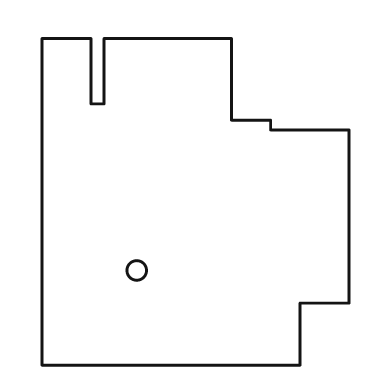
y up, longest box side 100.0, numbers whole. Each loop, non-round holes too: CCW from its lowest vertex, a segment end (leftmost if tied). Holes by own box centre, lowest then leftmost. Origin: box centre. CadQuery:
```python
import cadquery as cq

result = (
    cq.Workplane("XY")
    .moveTo(-47.0, -50.0)
    .lineTo(32.0, -50.0)
    .lineTo(32.0, -31.0)
    .lineTo(47.0, -31.0)
    .lineTo(47.0, 22.0)
    .lineTo(23.0, 22.0)
    .lineTo(23.0, 25.0)
    .lineTo(11.0, 25.0)
    .lineTo(11.0, 50.0)
    .lineTo(-28.0, 50.0)
    .lineTo(-28.0, 30.0)
    .lineTo(-32.0, 30.0)
    .lineTo(-32.0, 50.0)
    .lineTo(-47.0, 50.0)
    .close()
    .moveTo(-18.0, -21.0)
    .circle(3.0)
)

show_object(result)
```